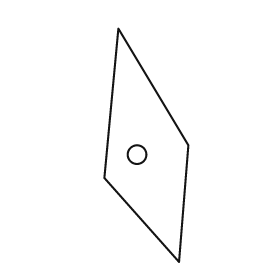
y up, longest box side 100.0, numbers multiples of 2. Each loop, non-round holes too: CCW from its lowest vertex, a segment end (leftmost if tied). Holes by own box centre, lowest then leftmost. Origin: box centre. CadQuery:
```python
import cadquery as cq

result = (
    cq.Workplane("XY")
    .moveTo(14.0, -50.0)
    .lineTo(18.0, 0.0)
    .lineTo(-12.0, 50.0)
    .lineTo(-18.0, -14.0)
    .close()
    .moveTo(-4.0, -4.0)
    .circle(4.0)
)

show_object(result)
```